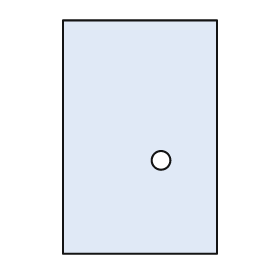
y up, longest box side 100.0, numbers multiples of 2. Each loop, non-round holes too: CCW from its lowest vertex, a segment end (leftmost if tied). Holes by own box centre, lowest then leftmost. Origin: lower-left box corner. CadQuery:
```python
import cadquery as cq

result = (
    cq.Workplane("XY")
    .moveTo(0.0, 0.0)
    .lineTo(66.0, 0.0)
    .lineTo(66.0, 100.0)
    .lineTo(0.0, 100.0)
    .close()
    .moveTo(42.0, 40.0)
    .circle(4.0)
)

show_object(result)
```